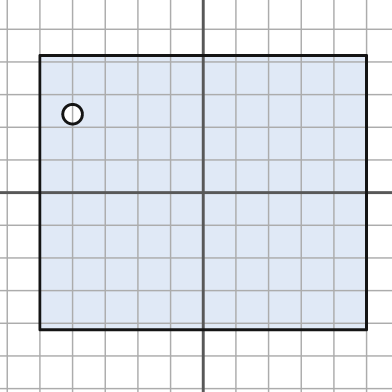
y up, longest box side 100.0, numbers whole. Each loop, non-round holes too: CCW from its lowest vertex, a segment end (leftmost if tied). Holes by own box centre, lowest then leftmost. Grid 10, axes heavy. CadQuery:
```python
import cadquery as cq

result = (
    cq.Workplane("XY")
    .moveTo(-50.0, -42.0)
    .lineTo(50.0, -42.0)
    .lineTo(50.0, 42.0)
    .lineTo(-50.0, 42.0)
    .close()
    .moveTo(-40.0, 24.0)
    .circle(3.0)
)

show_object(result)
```